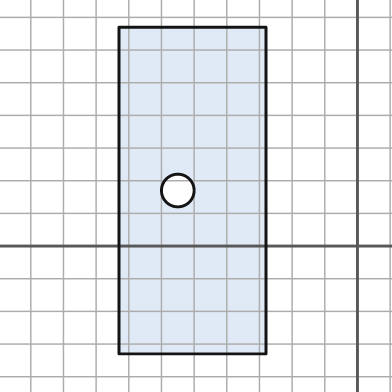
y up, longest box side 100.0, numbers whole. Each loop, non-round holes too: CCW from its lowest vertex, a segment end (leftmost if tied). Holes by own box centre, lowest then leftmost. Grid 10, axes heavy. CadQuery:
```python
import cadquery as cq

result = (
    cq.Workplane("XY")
    .moveTo(-73.0, -33.0)
    .lineTo(-28.0, -33.0)
    .lineTo(-28.0, 67.0)
    .lineTo(-73.0, 67.0)
    .close()
    .moveTo(-55.0, 17.0)
    .circle(5.0)
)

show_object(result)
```